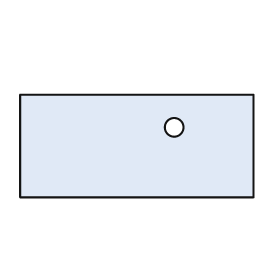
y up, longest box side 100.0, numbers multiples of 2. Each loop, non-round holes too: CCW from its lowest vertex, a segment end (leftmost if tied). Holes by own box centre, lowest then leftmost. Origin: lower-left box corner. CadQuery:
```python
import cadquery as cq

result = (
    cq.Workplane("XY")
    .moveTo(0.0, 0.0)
    .lineTo(100.0, 0.0)
    .lineTo(100.0, 44.0)
    .lineTo(0.0, 44.0)
    .close()
    .moveTo(66.0, 30.0)
    .circle(4.0)
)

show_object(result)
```